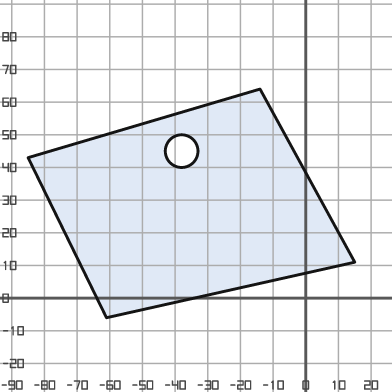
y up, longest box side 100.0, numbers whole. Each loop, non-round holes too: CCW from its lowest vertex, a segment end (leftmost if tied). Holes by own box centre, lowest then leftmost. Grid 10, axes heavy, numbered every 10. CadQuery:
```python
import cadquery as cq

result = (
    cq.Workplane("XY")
    .moveTo(-61.0, -6.0)
    .lineTo(15.0, 11.0)
    .lineTo(-14.0, 64.0)
    .lineTo(-85.0, 43.0)
    .close()
    .moveTo(-38.0, 45.0)
    .circle(5.0)
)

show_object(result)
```